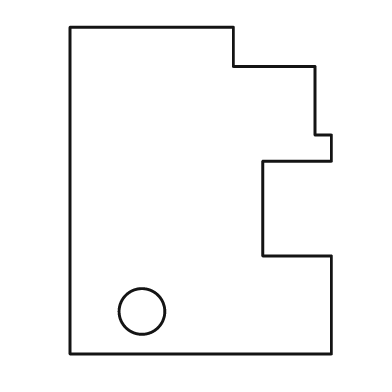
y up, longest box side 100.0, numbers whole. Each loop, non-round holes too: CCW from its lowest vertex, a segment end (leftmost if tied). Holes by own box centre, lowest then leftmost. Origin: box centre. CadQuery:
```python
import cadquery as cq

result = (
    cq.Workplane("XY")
    .moveTo(-40.0, -50.0)
    .lineTo(40.0, -50.0)
    .lineTo(40.0, -20.0)
    .lineTo(19.0, -20.0)
    .lineTo(19.0, 9.0)
    .lineTo(40.0, 9.0)
    .lineTo(40.0, 17.0)
    .lineTo(35.0, 17.0)
    .lineTo(35.0, 38.0)
    .lineTo(10.0, 38.0)
    .lineTo(10.0, 50.0)
    .lineTo(-40.0, 50.0)
    .close()
    .moveTo(-18.0, -37.0)
    .circle(7.0)
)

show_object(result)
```